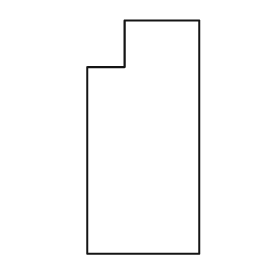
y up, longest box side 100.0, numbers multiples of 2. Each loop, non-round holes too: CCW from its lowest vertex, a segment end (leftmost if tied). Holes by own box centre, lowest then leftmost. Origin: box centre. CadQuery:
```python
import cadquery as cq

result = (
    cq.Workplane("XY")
    .moveTo(-24.0, -50.0)
    .lineTo(24.0, -50.0)
    .lineTo(24.0, 50.0)
    .lineTo(-8.0, 50.0)
    .lineTo(-8.0, 30.0)
    .lineTo(-24.0, 30.0)
    .close()
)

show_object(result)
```